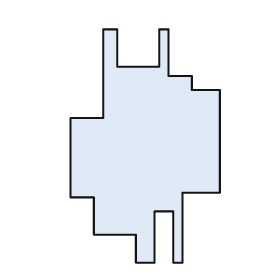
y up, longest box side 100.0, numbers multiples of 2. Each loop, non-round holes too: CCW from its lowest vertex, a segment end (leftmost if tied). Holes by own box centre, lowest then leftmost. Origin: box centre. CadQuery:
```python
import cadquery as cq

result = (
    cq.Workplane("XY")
    .moveTo(-4.0, -50.0)
    .lineTo(4.0, -50.0)
    .lineTo(4.0, -28.0)
    .lineTo(12.0, -28.0)
    .lineTo(12.0, -50.0)
    .lineTo(16.0, -50.0)
    .lineTo(16.0, -20.0)
    .lineTo(32.0, -20.0)
    .lineTo(32.0, 24.0)
    .lineTo(20.0, 24.0)
    .lineTo(20.0, 30.0)
    .lineTo(10.0, 30.0)
    .lineTo(10.0, 50.0)
    .lineTo(6.0, 50.0)
    .lineTo(6.0, 34.0)
    .lineTo(-12.0, 34.0)
    .lineTo(-12.0, 50.0)
    .lineTo(-18.0, 50.0)
    .lineTo(-18.0, 12.0)
    .lineTo(-32.0, 12.0)
    .lineTo(-32.0, -22.0)
    .lineTo(-22.0, -22.0)
    .lineTo(-22.0, -38.0)
    .lineTo(-4.0, -38.0)
    .close()
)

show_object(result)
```